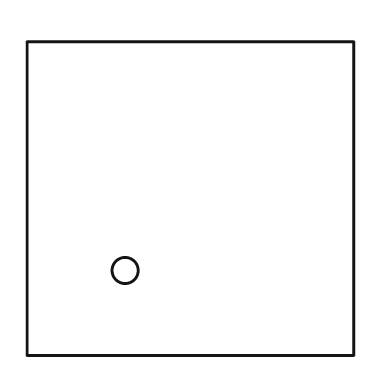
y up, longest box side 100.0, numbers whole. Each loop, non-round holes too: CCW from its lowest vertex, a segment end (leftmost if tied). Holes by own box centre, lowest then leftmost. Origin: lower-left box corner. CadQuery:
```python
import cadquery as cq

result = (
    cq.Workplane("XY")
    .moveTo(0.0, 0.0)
    .lineTo(100.0, 0.0)
    .lineTo(100.0, 96.0)
    .lineTo(0.0, 96.0)
    .close()
    .moveTo(30.0, 26.0)
    .circle(4.0)
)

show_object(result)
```